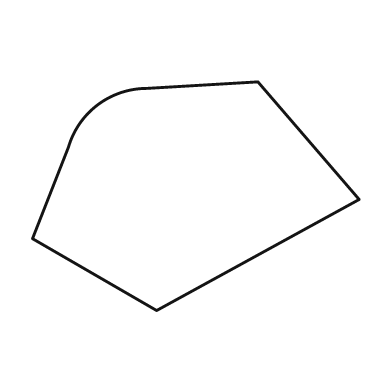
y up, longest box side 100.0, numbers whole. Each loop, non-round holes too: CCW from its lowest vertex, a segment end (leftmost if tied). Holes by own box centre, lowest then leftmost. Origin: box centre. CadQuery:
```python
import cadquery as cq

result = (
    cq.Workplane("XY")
    .moveTo(-12.0, -35.0)
    .lineTo(50.0, -1.0)
    .lineTo(19.0, 35.0)
    .lineTo(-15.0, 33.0)
    .threePointArc((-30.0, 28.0), (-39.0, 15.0))
    .lineTo(-50.0, -13.0)
    .close()
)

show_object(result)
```